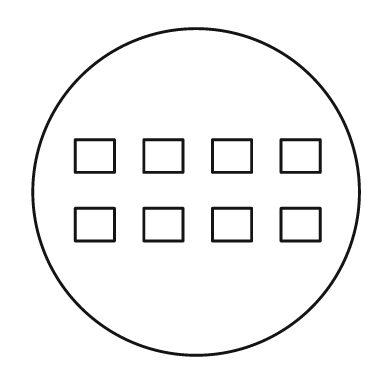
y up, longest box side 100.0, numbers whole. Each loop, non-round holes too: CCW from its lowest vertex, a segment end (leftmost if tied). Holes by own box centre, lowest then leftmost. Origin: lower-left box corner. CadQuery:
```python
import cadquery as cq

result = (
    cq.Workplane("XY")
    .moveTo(50.0, 50.0)
    .circle(50.0)
    .moveTo(13.0, 35.0)
    .lineTo(25.0, 35.0)
    .lineTo(25.0, 45.0)
    .lineTo(13.0, 45.0)
    .close()
    .moveTo(34.0, 35.0)
    .lineTo(46.0, 35.0)
    .lineTo(46.0, 45.0)
    .lineTo(34.0, 45.0)
    .close()
    .moveTo(55.0, 35.0)
    .lineTo(67.0, 35.0)
    .lineTo(67.0, 45.0)
    .lineTo(55.0, 45.0)
    .close()
    .moveTo(76.0, 35.0)
    .lineTo(88.0, 35.0)
    .lineTo(88.0, 45.0)
    .lineTo(76.0, 45.0)
    .close()
    .moveTo(13.0, 56.0)
    .lineTo(25.0, 56.0)
    .lineTo(25.0, 66.0)
    .lineTo(13.0, 66.0)
    .close()
    .moveTo(34.0, 56.0)
    .lineTo(46.0, 56.0)
    .lineTo(46.0, 66.0)
    .lineTo(34.0, 66.0)
    .close()
    .moveTo(55.0, 56.0)
    .lineTo(67.0, 56.0)
    .lineTo(67.0, 66.0)
    .lineTo(55.0, 66.0)
    .close()
    .moveTo(76.0, 56.0)
    .lineTo(88.0, 56.0)
    .lineTo(88.0, 66.0)
    .lineTo(76.0, 66.0)
    .close()
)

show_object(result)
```